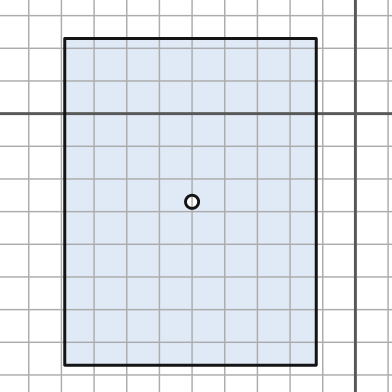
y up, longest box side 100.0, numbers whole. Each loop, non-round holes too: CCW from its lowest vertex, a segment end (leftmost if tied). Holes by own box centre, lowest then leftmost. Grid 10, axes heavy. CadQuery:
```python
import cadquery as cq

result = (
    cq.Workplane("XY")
    .moveTo(-89.0, -77.0)
    .lineTo(-12.0, -77.0)
    .lineTo(-12.0, 23.0)
    .lineTo(-89.0, 23.0)
    .close()
    .moveTo(-50.0, -27.0)
    .circle(2.0)
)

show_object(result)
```